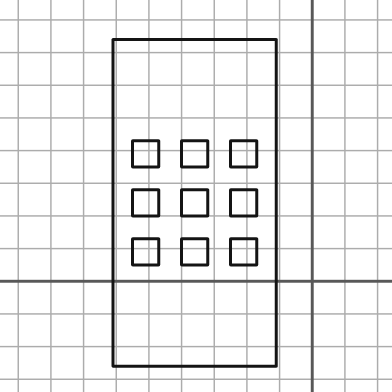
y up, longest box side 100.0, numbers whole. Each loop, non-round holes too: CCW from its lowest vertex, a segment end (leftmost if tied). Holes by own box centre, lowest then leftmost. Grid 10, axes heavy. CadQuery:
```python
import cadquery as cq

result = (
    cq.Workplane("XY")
    .moveTo(-61.0, -26.0)
    .lineTo(-11.0, -26.0)
    .lineTo(-11.0, 74.0)
    .lineTo(-61.0, 74.0)
    .close()
    .moveTo(-55.0, 5.0)
    .lineTo(-47.0, 5.0)
    .lineTo(-47.0, 13.0)
    .lineTo(-55.0, 13.0)
    .close()
    .moveTo(-40.0, 5.0)
    .lineTo(-32.0, 5.0)
    .lineTo(-32.0, 13.0)
    .lineTo(-40.0, 13.0)
    .close()
    .moveTo(-25.0, 5.0)
    .lineTo(-17.0, 5.0)
    .lineTo(-17.0, 13.0)
    .lineTo(-25.0, 13.0)
    .close()
    .moveTo(-55.0, 20.0)
    .lineTo(-47.0, 20.0)
    .lineTo(-47.0, 28.0)
    .lineTo(-55.0, 28.0)
    .close()
    .moveTo(-40.0, 20.0)
    .lineTo(-32.0, 20.0)
    .lineTo(-32.0, 28.0)
    .lineTo(-40.0, 28.0)
    .close()
    .moveTo(-25.0, 20.0)
    .lineTo(-17.0, 20.0)
    .lineTo(-17.0, 28.0)
    .lineTo(-25.0, 28.0)
    .close()
    .moveTo(-55.0, 35.0)
    .lineTo(-47.0, 35.0)
    .lineTo(-47.0, 43.0)
    .lineTo(-55.0, 43.0)
    .close()
    .moveTo(-40.0, 35.0)
    .lineTo(-32.0, 35.0)
    .lineTo(-32.0, 43.0)
    .lineTo(-40.0, 43.0)
    .close()
    .moveTo(-25.0, 35.0)
    .lineTo(-17.0, 35.0)
    .lineTo(-17.0, 43.0)
    .lineTo(-25.0, 43.0)
    .close()
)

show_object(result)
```